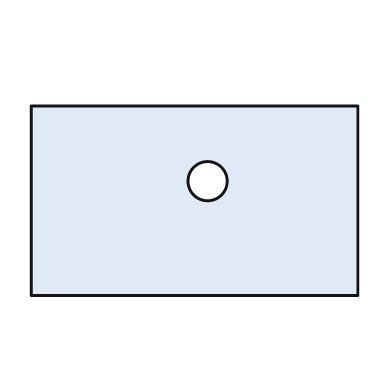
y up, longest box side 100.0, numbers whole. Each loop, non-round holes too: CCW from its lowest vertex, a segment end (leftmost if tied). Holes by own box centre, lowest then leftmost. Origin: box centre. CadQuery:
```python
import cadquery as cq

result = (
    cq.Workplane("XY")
    .moveTo(-50.0, -29.0)
    .lineTo(50.0, -29.0)
    .lineTo(50.0, 29.0)
    .lineTo(-50.0, 29.0)
    .close()
    .moveTo(4.0, 6.0)
    .circle(6.0)
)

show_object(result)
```